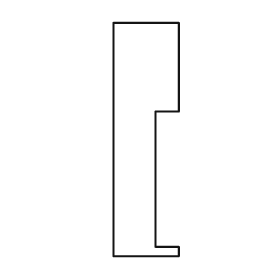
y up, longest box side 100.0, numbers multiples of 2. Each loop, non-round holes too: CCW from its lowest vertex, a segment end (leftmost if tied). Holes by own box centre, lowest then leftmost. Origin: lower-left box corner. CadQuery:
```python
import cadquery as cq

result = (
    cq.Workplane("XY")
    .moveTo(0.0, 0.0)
    .lineTo(28.0, 0.0)
    .lineTo(28.0, 4.0)
    .lineTo(18.0, 4.0)
    .lineTo(18.0, 62.0)
    .lineTo(28.0, 62.0)
    .lineTo(28.0, 100.0)
    .lineTo(0.0, 100.0)
    .close()
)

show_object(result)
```